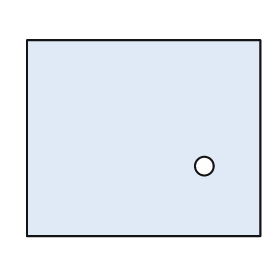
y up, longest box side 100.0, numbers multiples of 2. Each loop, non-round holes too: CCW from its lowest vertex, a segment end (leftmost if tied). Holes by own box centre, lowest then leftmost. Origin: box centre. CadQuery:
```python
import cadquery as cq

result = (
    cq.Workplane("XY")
    .moveTo(-50.0, -42.0)
    .lineTo(50.0, -42.0)
    .lineTo(50.0, 42.0)
    .lineTo(-50.0, 42.0)
    .close()
    .moveTo(26.0, -12.0)
    .circle(4.0)
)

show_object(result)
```